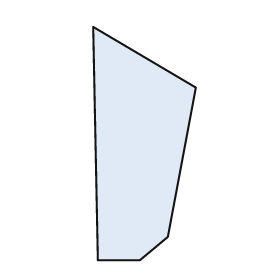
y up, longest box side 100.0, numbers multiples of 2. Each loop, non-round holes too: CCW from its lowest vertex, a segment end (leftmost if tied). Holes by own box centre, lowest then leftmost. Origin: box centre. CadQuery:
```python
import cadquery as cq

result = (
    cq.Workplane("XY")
    .moveTo(-20.0, -50.0)
    .lineTo(-2.0, -50.0)
    .lineTo(10.0, -40.0)
    .lineTo(22.0, 24.0)
    .lineTo(-22.0, 50.0)
    .close()
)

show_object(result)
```